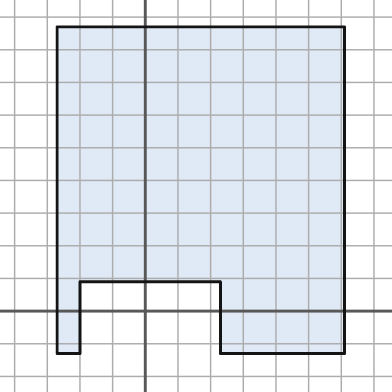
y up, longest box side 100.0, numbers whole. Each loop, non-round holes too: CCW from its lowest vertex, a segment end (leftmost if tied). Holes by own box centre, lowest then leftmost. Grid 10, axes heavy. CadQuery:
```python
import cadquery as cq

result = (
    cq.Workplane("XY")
    .moveTo(-27.0, -13.0)
    .lineTo(-20.0, -13.0)
    .lineTo(-20.0, 9.0)
    .lineTo(23.0, 9.0)
    .lineTo(23.0, -13.0)
    .lineTo(61.0, -13.0)
    .lineTo(61.0, 87.0)
    .lineTo(-27.0, 87.0)
    .close()
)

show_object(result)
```